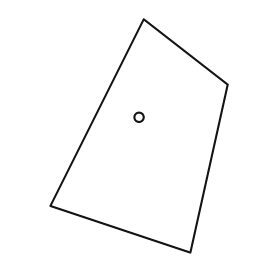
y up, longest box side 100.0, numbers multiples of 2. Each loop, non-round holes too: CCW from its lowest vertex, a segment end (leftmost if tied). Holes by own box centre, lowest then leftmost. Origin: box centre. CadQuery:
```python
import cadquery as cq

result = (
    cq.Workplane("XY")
    .moveTo(22.0, -50.0)
    .lineTo(38.0, 22.0)
    .lineTo(2.0, 50.0)
    .lineTo(-38.0, -30.0)
    .close()
    .moveTo(0.0, 8.0)
    .circle(2.0)
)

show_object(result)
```